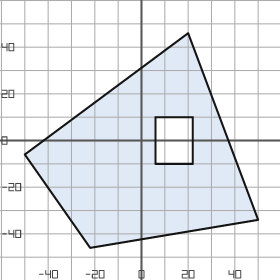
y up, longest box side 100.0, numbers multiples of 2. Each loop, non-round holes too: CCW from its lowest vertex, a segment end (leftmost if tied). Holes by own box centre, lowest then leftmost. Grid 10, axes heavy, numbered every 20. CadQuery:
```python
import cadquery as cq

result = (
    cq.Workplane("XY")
    .moveTo(-22.0, -46.0)
    .lineTo(50.0, -34.0)
    .lineTo(20.0, 46.0)
    .lineTo(-50.0, -6.0)
    .close()
    .moveTo(6.0, -10.0)
    .lineTo(22.0, -10.0)
    .lineTo(22.0, 10.0)
    .lineTo(6.0, 10.0)
    .close()
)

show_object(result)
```